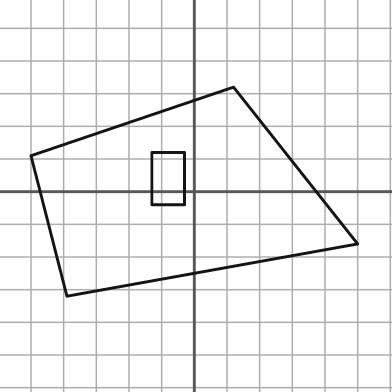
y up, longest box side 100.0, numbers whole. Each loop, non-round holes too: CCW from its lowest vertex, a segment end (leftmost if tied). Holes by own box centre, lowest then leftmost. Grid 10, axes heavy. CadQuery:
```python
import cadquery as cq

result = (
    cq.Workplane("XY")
    .moveTo(-39.0, -32.0)
    .lineTo(50.0, -16.0)
    .lineTo(12.0, 32.0)
    .lineTo(-50.0, 11.0)
    .close()
    .moveTo(-13.0, -4.0)
    .lineTo(-3.0, -4.0)
    .lineTo(-3.0, 12.0)
    .lineTo(-13.0, 12.0)
    .close()
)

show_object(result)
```